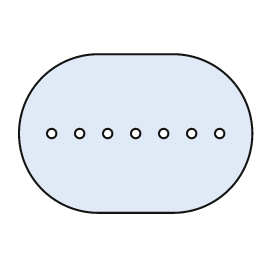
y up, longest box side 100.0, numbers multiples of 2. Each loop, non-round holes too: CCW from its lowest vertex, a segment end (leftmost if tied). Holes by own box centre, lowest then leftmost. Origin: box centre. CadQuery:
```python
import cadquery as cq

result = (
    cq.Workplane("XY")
    .moveTo(-16.0, -34.0)
    .lineTo(16.0, -34.0)
    .threePointArc((50.0, 0.0), (16.0, 34.0))
    .lineTo(-16.0, 34.0)
    .threePointArc((-50.0, 0.0), (-16.0, -34.0))
    .close()
    .moveTo(-36.0, 0.0)
    .circle(2.0)
    .moveTo(-24.0, 0.0)
    .circle(2.0)
    .moveTo(-12.0, 0.0)
    .circle(2.0)
    .moveTo(0.0, 0.0)
    .circle(2.0)
    .moveTo(12.0, 0.0)
    .circle(2.0)
    .moveTo(24.0, 0.0)
    .circle(2.0)
    .moveTo(36.0, 0.0)
    .circle(2.0)
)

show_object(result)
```